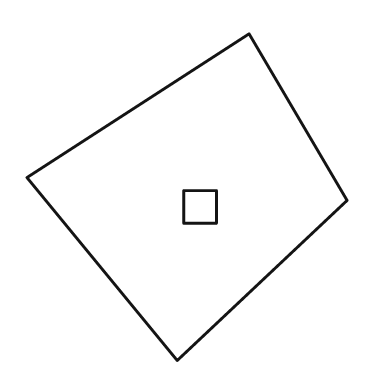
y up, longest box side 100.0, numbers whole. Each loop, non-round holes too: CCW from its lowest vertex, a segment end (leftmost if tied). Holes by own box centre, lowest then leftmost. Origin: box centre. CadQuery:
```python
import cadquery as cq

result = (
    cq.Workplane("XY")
    .moveTo(-3.0, -50.0)
    .lineTo(49.0, -1.0)
    .lineTo(19.0, 50.0)
    .lineTo(-49.0, 6.0)
    .close()
    .moveTo(-1.0, -8.0)
    .lineTo(9.0, -8.0)
    .lineTo(9.0, 2.0)
    .lineTo(-1.0, 2.0)
    .close()
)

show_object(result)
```